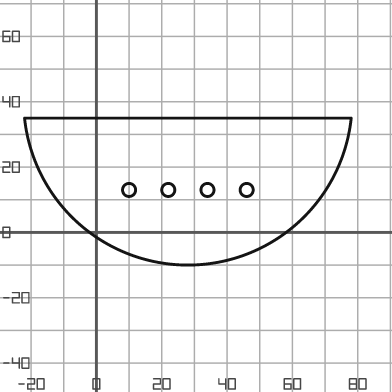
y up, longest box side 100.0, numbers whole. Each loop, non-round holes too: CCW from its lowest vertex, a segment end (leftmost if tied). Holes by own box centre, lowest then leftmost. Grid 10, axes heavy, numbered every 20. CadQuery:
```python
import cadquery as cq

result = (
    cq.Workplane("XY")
    .moveTo(-22.0, 35.0)
    .threePointArc((28.0, -10.0), (78.0, 35.0))
    .close()
    .moveTo(10.0, 13.0)
    .circle(2.0)
    .moveTo(22.0, 13.0)
    .circle(2.0)
    .moveTo(34.0, 13.0)
    .circle(2.0)
    .moveTo(46.0, 13.0)
    .circle(2.0)
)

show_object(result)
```